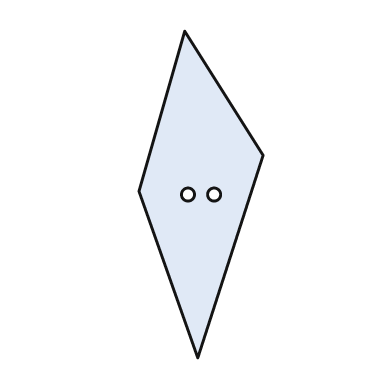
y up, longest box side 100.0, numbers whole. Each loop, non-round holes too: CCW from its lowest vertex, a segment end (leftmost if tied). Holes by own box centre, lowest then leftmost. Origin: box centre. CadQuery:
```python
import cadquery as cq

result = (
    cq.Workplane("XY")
    .moveTo(-1.0, -50.0)
    .lineTo(19.0, 12.0)
    .lineTo(-5.0, 50.0)
    .lineTo(-19.0, 1.0)
    .close()
    .moveTo(-4.0, 0.0)
    .circle(2.0)
    .moveTo(4.0, 0.0)
    .circle(2.0)
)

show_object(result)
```